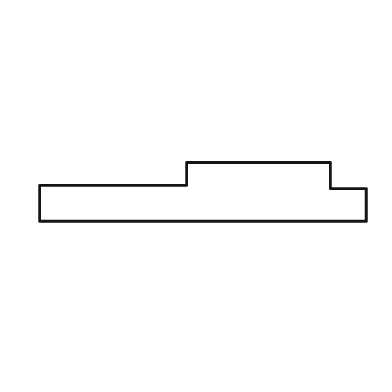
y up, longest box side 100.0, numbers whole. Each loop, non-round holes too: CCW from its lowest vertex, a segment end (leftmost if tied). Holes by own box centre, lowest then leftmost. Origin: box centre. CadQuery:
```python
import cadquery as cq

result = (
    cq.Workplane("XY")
    .moveTo(-50.0, -9.0)
    .lineTo(50.0, -9.0)
    .lineTo(50.0, 1.0)
    .lineTo(39.0, 1.0)
    .lineTo(39.0, 9.0)
    .lineTo(-5.0, 9.0)
    .lineTo(-5.0, 2.0)
    .lineTo(-50.0, 2.0)
    .close()
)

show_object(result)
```